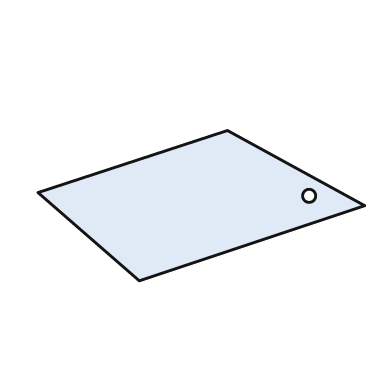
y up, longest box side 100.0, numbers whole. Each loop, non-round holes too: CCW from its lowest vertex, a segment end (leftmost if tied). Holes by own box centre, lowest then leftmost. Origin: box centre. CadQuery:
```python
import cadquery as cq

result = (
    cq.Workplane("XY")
    .moveTo(-19.0, -23.0)
    .lineTo(50.0, 0.0)
    .lineTo(8.0, 23.0)
    .lineTo(-50.0, 4.0)
    .close()
    .moveTo(33.0, 3.0)
    .circle(2.0)
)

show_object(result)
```